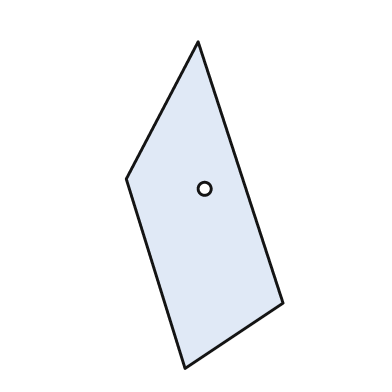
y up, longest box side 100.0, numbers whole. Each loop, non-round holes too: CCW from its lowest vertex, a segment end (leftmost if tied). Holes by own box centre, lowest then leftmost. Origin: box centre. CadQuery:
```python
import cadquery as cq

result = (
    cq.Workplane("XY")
    .moveTo(-6.0, -50.0)
    .lineTo(24.0, -30.0)
    .lineTo(-2.0, 50.0)
    .lineTo(-24.0, 8.0)
    .close()
    .moveTo(0.0, 5.0)
    .circle(2.0)
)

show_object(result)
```